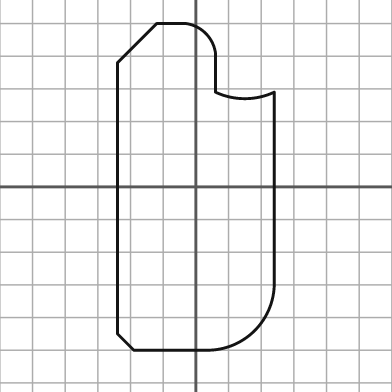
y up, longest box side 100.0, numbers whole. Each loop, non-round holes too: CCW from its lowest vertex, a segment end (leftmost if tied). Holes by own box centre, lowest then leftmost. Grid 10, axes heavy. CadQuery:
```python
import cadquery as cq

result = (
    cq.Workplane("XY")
    .moveTo(-19.0, -50.0)
    .lineTo(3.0, -50.0)
    .threePointArc((18.0, -44.0), (24.0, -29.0))
    .lineTo(24.0, 29.0)
    .threePointArc((15.0, 27.0), (6.0, 29.0))
    .lineTo(6.0, 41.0)
    .threePointArc((3.0, 47.0), (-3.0, 50.0))
    .lineTo(-12.0, 50.0)
    .lineTo(-24.0, 38.0)
    .lineTo(-24.0, -45.0)
    .close()
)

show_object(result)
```